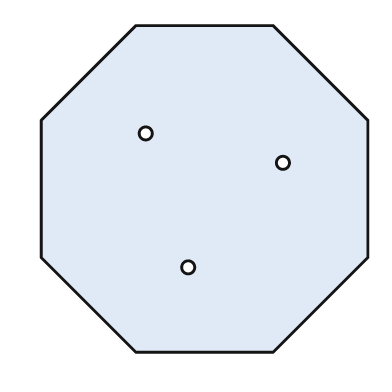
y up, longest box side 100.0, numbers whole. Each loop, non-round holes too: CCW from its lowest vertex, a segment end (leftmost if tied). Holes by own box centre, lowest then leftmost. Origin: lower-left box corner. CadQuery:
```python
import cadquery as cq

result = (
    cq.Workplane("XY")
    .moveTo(29.0, 0.0)
    .lineTo(71.0, 0.0)
    .lineTo(100.0, 29.0)
    .lineTo(100.0, 71.0)
    .lineTo(71.0, 100.0)
    .lineTo(29.0, 100.0)
    .lineTo(0.0, 71.0)
    .lineTo(0.0, 29.0)
    .close()
    .moveTo(45.0, 26.0)
    .circle(2.0)
    .moveTo(74.0, 58.0)
    .circle(2.0)
    .moveTo(32.0, 67.0)
    .circle(2.0)
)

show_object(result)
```